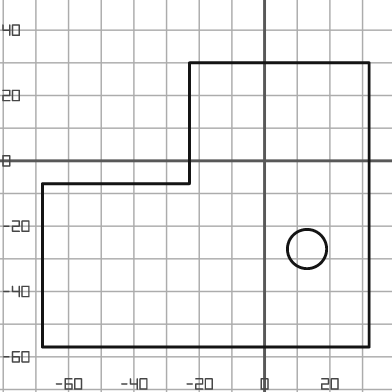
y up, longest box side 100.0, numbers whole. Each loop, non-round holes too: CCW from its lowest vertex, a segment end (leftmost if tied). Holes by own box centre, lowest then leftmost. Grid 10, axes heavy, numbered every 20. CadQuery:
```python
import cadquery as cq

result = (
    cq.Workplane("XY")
    .moveTo(-68.0, -57.0)
    .lineTo(32.0, -57.0)
    .lineTo(32.0, 30.0)
    .lineTo(-23.0, 30.0)
    .lineTo(-23.0, -7.0)
    .lineTo(-68.0, -7.0)
    .close()
    .moveTo(13.0, -27.0)
    .circle(6.0)
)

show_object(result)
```